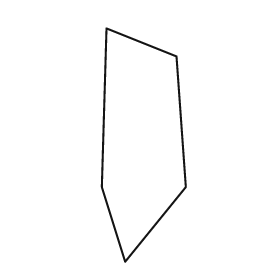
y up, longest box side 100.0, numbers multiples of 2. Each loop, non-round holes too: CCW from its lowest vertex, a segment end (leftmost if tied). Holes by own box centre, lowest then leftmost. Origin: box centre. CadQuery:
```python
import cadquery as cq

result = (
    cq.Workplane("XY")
    .moveTo(-8.0, -50.0)
    .lineTo(18.0, -18.0)
    .lineTo(14.0, 38.0)
    .lineTo(-16.0, 50.0)
    .lineTo(-18.0, -18.0)
    .close()
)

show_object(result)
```